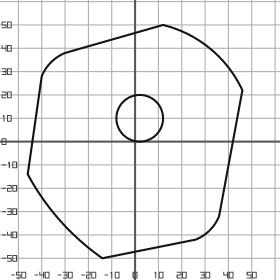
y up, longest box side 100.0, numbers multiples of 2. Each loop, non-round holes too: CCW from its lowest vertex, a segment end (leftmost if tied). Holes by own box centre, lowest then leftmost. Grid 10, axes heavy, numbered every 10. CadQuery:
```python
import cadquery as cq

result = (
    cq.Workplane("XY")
    .moveTo(-14.0, -50.0)
    .lineTo(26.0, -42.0)
    .threePointArc((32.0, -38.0), (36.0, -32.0))
    .lineTo(46.0, 22.0)
    .threePointArc((32.0, 40.0), (12.0, 50.0))
    .lineTo(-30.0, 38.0)
    .threePointArc((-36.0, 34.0), (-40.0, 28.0))
    .lineTo(-46.0, -14.0)
    .threePointArc((-32.0, -34.0), (-14.0, -50.0))
    .close()
    .moveTo(2.0, 10.0)
    .circle(10.0)
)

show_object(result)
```